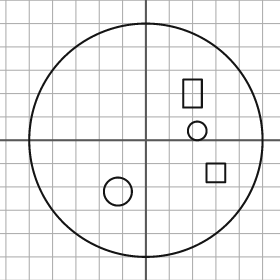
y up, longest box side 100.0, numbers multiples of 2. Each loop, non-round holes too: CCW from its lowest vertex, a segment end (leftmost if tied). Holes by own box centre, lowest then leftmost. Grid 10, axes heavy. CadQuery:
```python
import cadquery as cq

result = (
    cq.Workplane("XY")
    .moveTo(0.0, 0.0)
    .circle(50.0)
    .moveTo(-12.0, -22.0)
    .circle(6.0)
    .moveTo(26.0, -18.0)
    .lineTo(34.0, -18.0)
    .lineTo(34.0, -10.0)
    .lineTo(26.0, -10.0)
    .close()
    .moveTo(22.0, 4.0)
    .circle(4.0)
    .moveTo(16.0, 14.0)
    .lineTo(24.0, 14.0)
    .lineTo(24.0, 26.0)
    .lineTo(16.0, 26.0)
    .close()
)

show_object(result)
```